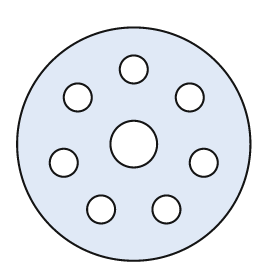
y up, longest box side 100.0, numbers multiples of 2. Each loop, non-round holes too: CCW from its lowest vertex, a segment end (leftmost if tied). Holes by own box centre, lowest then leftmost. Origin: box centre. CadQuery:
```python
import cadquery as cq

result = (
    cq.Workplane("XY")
    .moveTo(0.0, 0.0)
    .circle(50.0)
    .moveTo(-14.0, -28.0)
    .circle(6.0)
    .moveTo(14.0, -28.0)
    .circle(6.0)
    .moveTo(-30.0, -8.0)
    .circle(6.0)
    .moveTo(30.0, -8.0)
    .circle(6.0)
    .moveTo(0.0, 0.0)
    .circle(10.0)
    .moveTo(-24.0, 20.0)
    .circle(6.0)
    .moveTo(24.0, 20.0)
    .circle(6.0)
    .moveTo(0.0, 32.0)
    .circle(6.0)
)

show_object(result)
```